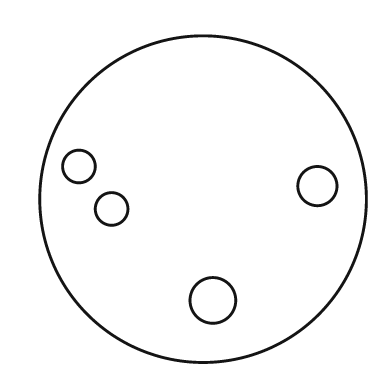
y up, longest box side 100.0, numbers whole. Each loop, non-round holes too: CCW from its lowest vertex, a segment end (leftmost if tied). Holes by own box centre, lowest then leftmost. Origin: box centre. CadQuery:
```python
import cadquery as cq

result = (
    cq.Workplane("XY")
    .moveTo(0.0, 0.0)
    .circle(50.0)
    .moveTo(3.0, -31.0)
    .circle(7.0)
    .moveTo(-28.0, -3.0)
    .circle(5.0)
    .moveTo(35.0, 4.0)
    .circle(6.0)
    .moveTo(-38.0, 10.0)
    .circle(5.0)
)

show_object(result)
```